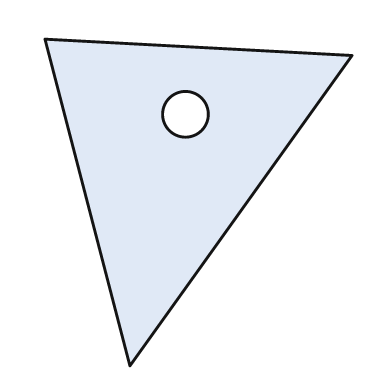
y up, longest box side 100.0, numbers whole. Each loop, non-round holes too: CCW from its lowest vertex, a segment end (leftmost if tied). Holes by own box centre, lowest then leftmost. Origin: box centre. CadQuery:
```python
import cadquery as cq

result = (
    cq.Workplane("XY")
    .moveTo(-21.0, -50.0)
    .lineTo(47.0, 45.0)
    .lineTo(-47.0, 50.0)
    .close()
    .moveTo(-4.0, 27.0)
    .circle(7.0)
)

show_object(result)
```